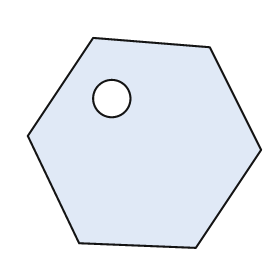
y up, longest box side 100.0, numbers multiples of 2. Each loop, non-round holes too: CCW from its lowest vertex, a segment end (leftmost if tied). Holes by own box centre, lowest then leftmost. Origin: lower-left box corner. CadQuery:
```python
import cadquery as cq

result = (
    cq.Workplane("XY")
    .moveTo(72.0, 0.0)
    .lineTo(100.0, 42.0)
    .lineTo(78.0, 86.0)
    .lineTo(28.0, 90.0)
    .lineTo(0.0, 48.0)
    .lineTo(22.0, 2.0)
    .close()
    .moveTo(36.0, 64.0)
    .circle(8.0)
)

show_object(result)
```